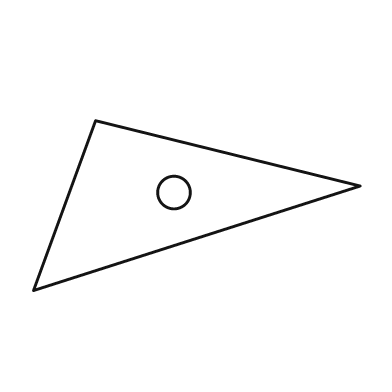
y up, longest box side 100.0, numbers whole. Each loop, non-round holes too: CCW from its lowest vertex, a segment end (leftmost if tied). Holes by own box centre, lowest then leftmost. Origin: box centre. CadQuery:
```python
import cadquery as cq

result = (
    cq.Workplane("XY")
    .moveTo(-50.0, -26.0)
    .lineTo(50.0, 6.0)
    .lineTo(-31.0, 26.0)
    .close()
    .moveTo(-7.0, 4.0)
    .circle(5.0)
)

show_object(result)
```